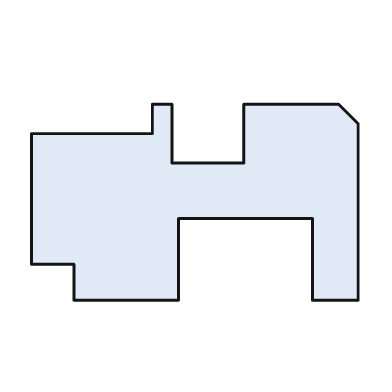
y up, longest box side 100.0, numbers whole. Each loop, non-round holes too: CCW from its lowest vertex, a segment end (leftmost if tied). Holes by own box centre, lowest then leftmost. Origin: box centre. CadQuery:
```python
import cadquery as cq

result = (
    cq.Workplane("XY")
    .moveTo(-37.0, -30.0)
    .lineTo(-5.0, -30.0)
    .lineTo(-5.0, -5.0)
    .lineTo(36.0, -5.0)
    .lineTo(36.0, -30.0)
    .lineTo(50.0, -30.0)
    .lineTo(50.0, 24.0)
    .lineTo(44.0, 30.0)
    .lineTo(15.0, 30.0)
    .lineTo(15.0, 12.0)
    .lineTo(-7.0, 12.0)
    .lineTo(-7.0, 30.0)
    .lineTo(-13.0, 30.0)
    .lineTo(-13.0, 21.0)
    .lineTo(-50.0, 21.0)
    .lineTo(-50.0, -19.0)
    .lineTo(-37.0, -19.0)
    .close()
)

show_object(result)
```